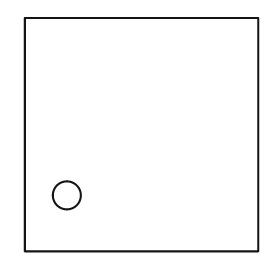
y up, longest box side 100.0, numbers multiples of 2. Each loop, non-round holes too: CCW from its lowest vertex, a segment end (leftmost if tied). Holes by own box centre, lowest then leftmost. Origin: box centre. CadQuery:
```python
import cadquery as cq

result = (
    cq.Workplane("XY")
    .moveTo(-50.0, -50.0)
    .lineTo(50.0, -50.0)
    .lineTo(50.0, 50.0)
    .lineTo(-50.0, 50.0)
    .close()
    .moveTo(-32.0, -26.0)
    .circle(6.0)
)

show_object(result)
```